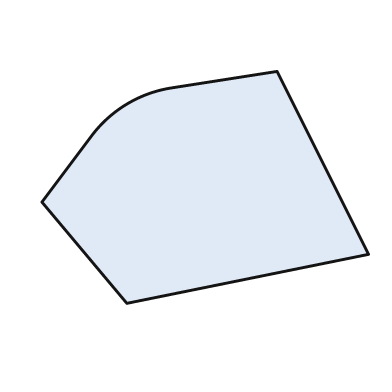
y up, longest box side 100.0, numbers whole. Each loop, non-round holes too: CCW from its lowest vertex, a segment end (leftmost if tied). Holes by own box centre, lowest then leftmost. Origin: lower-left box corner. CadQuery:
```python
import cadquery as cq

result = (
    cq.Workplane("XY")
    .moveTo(26.0, 0.0)
    .lineTo(100.0, 15.0)
    .lineTo(72.0, 71.0)
    .lineTo(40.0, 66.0)
    .threePointArc((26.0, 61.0), (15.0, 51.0))
    .lineTo(0.0, 31.0)
    .close()
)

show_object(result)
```